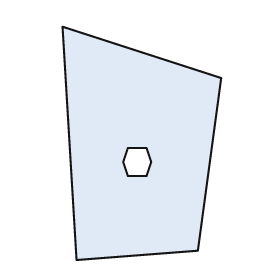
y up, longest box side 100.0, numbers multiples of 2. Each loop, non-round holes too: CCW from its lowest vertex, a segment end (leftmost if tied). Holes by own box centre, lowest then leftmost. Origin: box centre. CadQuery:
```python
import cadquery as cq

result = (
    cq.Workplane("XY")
    .moveTo(-28.0, -50.0)
    .lineTo(24.0, -46.0)
    .lineTo(34.0, 28.0)
    .lineTo(-34.0, 50.0)
    .close()
    .moveTo(-6.0, -14.0)
    .lineTo(2.0, -14.0)
    .lineTo(4.0, -8.0)
    .lineTo(2.0, -2.0)
    .lineTo(-6.0, -2.0)
    .lineTo(-8.0, -8.0)
    .close()
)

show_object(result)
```